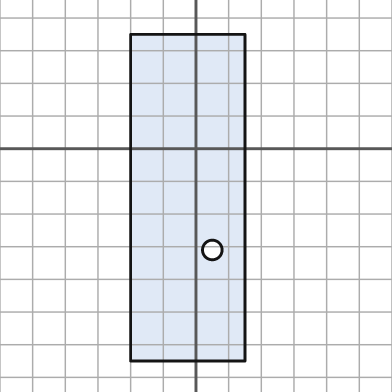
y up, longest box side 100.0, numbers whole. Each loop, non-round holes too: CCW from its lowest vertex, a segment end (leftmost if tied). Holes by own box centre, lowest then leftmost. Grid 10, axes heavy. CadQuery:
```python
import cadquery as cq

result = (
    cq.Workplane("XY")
    .moveTo(-20.0, -65.0)
    .lineTo(15.0, -65.0)
    .lineTo(15.0, 35.0)
    .lineTo(-20.0, 35.0)
    .close()
    .moveTo(5.0, -31.0)
    .circle(3.0)
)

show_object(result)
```